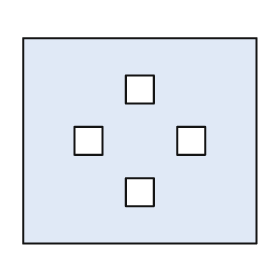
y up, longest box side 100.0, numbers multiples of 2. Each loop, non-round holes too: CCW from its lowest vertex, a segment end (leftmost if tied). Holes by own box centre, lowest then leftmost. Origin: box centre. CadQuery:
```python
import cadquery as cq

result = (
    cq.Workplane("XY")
    .moveTo(-50.0, -44.0)
    .lineTo(50.0, -44.0)
    .lineTo(50.0, 44.0)
    .lineTo(-50.0, 44.0)
    .close()
    .moveTo(-6.0, -28.0)
    .lineTo(6.0, -28.0)
    .lineTo(6.0, -16.0)
    .lineTo(-6.0, -16.0)
    .close()
    .moveTo(-28.0, -6.0)
    .lineTo(-16.0, -6.0)
    .lineTo(-16.0, 6.0)
    .lineTo(-28.0, 6.0)
    .close()
    .moveTo(16.0, -6.0)
    .lineTo(28.0, -6.0)
    .lineTo(28.0, 6.0)
    .lineTo(16.0, 6.0)
    .close()
    .moveTo(-6.0, 16.0)
    .lineTo(6.0, 16.0)
    .lineTo(6.0, 28.0)
    .lineTo(-6.0, 28.0)
    .close()
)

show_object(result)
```